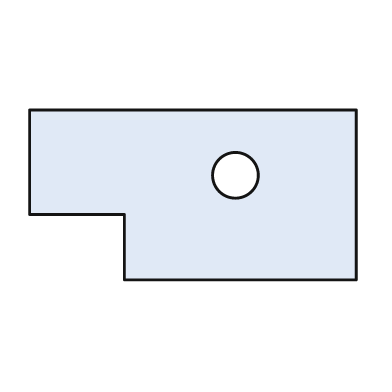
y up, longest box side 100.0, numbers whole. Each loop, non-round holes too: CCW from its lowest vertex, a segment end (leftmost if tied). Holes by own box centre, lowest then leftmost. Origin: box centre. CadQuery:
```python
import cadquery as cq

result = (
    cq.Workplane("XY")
    .moveTo(-21.0, -26.0)
    .lineTo(50.0, -26.0)
    .lineTo(50.0, 26.0)
    .lineTo(-50.0, 26.0)
    .lineTo(-50.0, -6.0)
    .lineTo(-21.0, -6.0)
    .close()
    .moveTo(13.0, 6.0)
    .circle(7.0)
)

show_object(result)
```